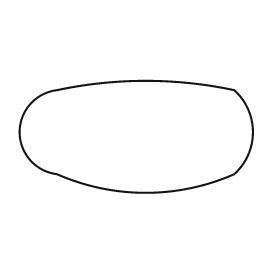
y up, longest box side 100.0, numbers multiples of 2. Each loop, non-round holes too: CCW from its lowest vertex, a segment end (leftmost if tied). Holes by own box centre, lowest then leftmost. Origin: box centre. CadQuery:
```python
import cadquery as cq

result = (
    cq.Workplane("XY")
    .moveTo(-34.0, -16.0)
    .threePointArc((4.0, -24.0), (42.0, -16.0))
    .threePointArc((50.0, 2.0), (42.0, 20.0))
    .threePointArc((4.0, 24.0), (-34.0, 20.0))
    .threePointArc((-50.0, 2.0), (-34.0, -16.0))
    .close()
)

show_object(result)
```